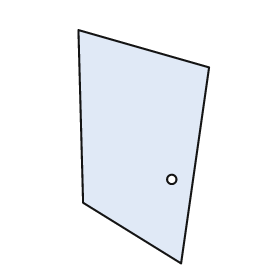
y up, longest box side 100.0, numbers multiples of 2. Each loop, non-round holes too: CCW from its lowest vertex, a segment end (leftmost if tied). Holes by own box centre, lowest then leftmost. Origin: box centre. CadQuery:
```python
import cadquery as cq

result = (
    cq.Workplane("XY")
    .moveTo(16.0, -50.0)
    .lineTo(28.0, 34.0)
    .lineTo(-28.0, 50.0)
    .lineTo(-26.0, -24.0)
    .close()
    .moveTo(12.0, -14.0)
    .circle(2.0)
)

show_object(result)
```